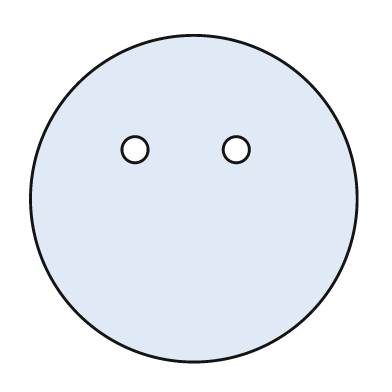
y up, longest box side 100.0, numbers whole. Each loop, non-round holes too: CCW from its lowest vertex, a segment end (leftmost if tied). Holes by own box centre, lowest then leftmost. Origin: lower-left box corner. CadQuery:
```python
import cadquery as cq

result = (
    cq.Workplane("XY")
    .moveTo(50.0, 50.0)
    .circle(50.0)
    .moveTo(32.0, 65.0)
    .circle(4.0)
    .moveTo(63.0, 65.0)
    .circle(4.0)
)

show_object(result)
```